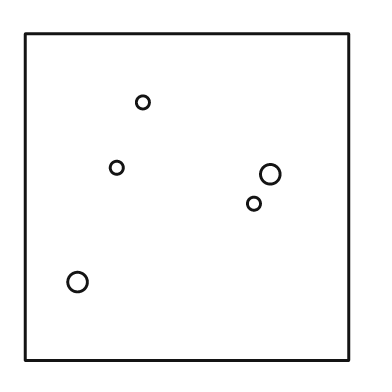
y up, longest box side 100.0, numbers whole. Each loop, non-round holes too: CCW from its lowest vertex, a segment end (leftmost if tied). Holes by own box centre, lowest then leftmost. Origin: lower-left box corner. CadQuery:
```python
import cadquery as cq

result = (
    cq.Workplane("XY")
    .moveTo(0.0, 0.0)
    .lineTo(99.0, 0.0)
    .lineTo(99.0, 100.0)
    .lineTo(0.0, 100.0)
    .close()
    .moveTo(16.0, 24.0)
    .circle(3.0)
    .moveTo(70.0, 48.0)
    .circle(2.0)
    .moveTo(75.0, 57.0)
    .circle(3.0)
    .moveTo(28.0, 59.0)
    .circle(2.0)
    .moveTo(36.0, 79.0)
    .circle(2.0)
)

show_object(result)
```